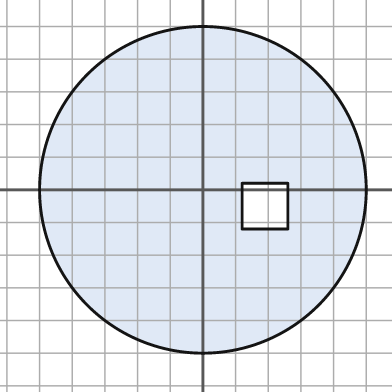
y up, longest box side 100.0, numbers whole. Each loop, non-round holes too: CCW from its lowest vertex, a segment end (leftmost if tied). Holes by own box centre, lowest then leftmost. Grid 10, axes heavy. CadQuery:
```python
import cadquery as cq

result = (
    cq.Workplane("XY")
    .moveTo(0.0, 0.0)
    .circle(50.0)
    .moveTo(12.0, -12.0)
    .lineTo(26.0, -12.0)
    .lineTo(26.0, 2.0)
    .lineTo(12.0, 2.0)
    .close()
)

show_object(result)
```